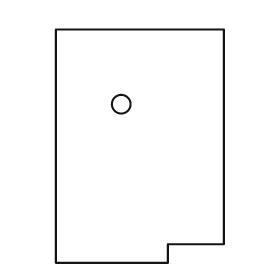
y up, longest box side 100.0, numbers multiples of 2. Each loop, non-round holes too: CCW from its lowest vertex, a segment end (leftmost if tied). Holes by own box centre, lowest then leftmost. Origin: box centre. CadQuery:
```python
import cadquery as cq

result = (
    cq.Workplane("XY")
    .moveTo(-36.0, -50.0)
    .lineTo(12.0, -50.0)
    .lineTo(12.0, -42.0)
    .lineTo(36.0, -42.0)
    .lineTo(36.0, 50.0)
    .lineTo(-36.0, 50.0)
    .close()
    .moveTo(-8.0, 18.0)
    .circle(4.0)
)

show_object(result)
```